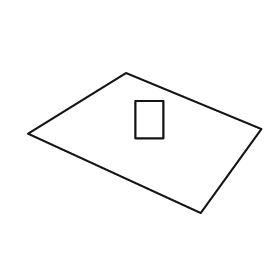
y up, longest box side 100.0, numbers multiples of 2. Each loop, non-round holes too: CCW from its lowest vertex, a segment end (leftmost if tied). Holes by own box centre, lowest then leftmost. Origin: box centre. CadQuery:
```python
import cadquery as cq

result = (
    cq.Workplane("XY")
    .moveTo(24.0, -30.0)
    .lineTo(50.0, 6.0)
    .lineTo(-8.0, 30.0)
    .lineTo(-50.0, 4.0)
    .close()
    .moveTo(-4.0, 2.0)
    .lineTo(8.0, 2.0)
    .lineTo(8.0, 18.0)
    .lineTo(-4.0, 18.0)
    .close()
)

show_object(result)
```